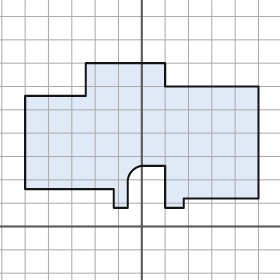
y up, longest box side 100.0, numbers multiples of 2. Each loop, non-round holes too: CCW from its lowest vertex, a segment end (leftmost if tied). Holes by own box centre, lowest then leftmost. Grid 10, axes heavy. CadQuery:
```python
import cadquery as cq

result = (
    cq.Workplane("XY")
    .moveTo(-12.0, 8.0)
    .lineTo(-6.0, 8.0)
    .lineTo(-6.0, 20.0)
    .threePointArc((-4.0, 24.0), (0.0, 26.0))
    .lineTo(10.0, 26.0)
    .lineTo(10.0, 8.0)
    .lineTo(18.0, 8.0)
    .lineTo(18.0, 12.0)
    .lineTo(50.0, 12.0)
    .lineTo(50.0, 60.0)
    .lineTo(10.0, 60.0)
    .lineTo(10.0, 70.0)
    .lineTo(-24.0, 70.0)
    .lineTo(-24.0, 56.0)
    .lineTo(-50.0, 56.0)
    .lineTo(-50.0, 16.0)
    .lineTo(-12.0, 16.0)
    .close()
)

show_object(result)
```